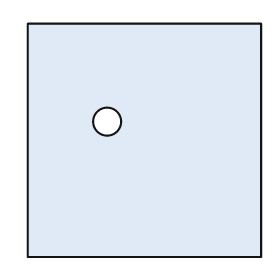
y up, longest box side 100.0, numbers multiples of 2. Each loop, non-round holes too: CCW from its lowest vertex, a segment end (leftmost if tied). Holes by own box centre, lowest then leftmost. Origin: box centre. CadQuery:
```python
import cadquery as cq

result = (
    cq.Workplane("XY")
    .moveTo(-50.0, -50.0)
    .lineTo(50.0, -50.0)
    .lineTo(50.0, 50.0)
    .lineTo(-50.0, 50.0)
    .close()
    .moveTo(-16.0, 8.0)
    .circle(6.0)
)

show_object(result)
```